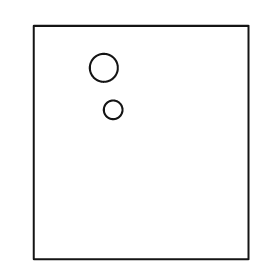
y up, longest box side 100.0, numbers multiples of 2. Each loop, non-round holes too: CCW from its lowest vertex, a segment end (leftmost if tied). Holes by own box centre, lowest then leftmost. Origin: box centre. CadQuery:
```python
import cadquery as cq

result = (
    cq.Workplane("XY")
    .moveTo(-46.0, -50.0)
    .lineTo(46.0, -50.0)
    .lineTo(46.0, 50.0)
    .lineTo(-46.0, 50.0)
    .close()
    .moveTo(-12.0, 14.0)
    .circle(4.0)
    .moveTo(-16.0, 32.0)
    .circle(6.0)
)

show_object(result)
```